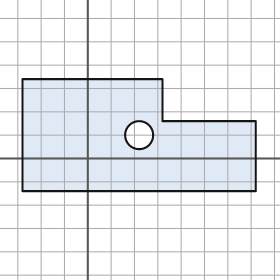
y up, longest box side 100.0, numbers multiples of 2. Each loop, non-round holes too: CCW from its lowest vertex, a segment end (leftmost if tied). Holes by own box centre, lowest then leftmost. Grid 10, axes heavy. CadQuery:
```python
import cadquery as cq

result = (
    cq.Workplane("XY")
    .moveTo(-28.0, -14.0)
    .lineTo(72.0, -14.0)
    .lineTo(72.0, 16.0)
    .lineTo(32.0, 16.0)
    .lineTo(32.0, 34.0)
    .lineTo(-28.0, 34.0)
    .close()
    .moveTo(22.0, 10.0)
    .circle(6.0)
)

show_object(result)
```